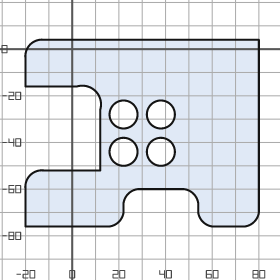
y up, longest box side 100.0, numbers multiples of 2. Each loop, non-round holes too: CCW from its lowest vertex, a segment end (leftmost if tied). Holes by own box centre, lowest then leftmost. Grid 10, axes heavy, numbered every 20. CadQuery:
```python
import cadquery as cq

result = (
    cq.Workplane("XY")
    .moveTo(-20.0, -76.0)
    .lineTo(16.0, -76.0)
    .threePointArc((20.0, -74.0), (22.0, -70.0))
    .lineTo(22.0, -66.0)
    .threePointArc((24.0, -62.0), (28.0, -60.0))
    .lineTo(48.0, -60.0)
    .threePointArc((52.0, -62.0), (54.0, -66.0))
    .lineTo(54.0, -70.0)
    .threePointArc((56.0, -74.0), (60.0, -76.0))
    .lineTo(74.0, -76.0)
    .threePointArc((78.0, -74.0), (80.0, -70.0))
    .lineTo(80.0, 4.0)
    .lineTo(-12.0, 4.0)
    .threePointArc((-18.0, 2.0), (-20.0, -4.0))
    .lineTo(-20.0, -16.0)
    .lineTo(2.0, -16.0)
    .threePointArc((10.0, -18.0), (12.0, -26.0))
    .lineTo(12.0, -52.0)
    .lineTo(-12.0, -52.0)
    .threePointArc((-18.0, -54.0), (-20.0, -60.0))
    .close()
    .moveTo(22.0, -44.0)
    .circle(6.0)
    .moveTo(38.0, -44.0)
    .circle(6.0)
    .moveTo(22.0, -28.0)
    .circle(6.0)
    .moveTo(38.0, -28.0)
    .circle(6.0)
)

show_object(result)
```